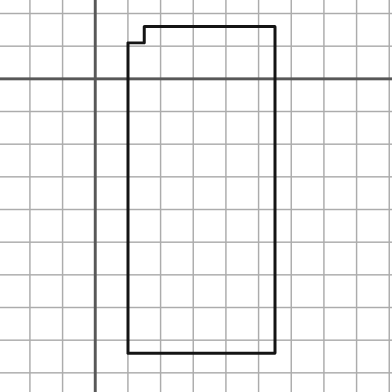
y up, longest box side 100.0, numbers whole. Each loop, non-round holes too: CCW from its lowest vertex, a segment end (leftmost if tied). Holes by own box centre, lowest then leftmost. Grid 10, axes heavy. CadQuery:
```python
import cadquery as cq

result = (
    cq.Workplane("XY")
    .moveTo(10.0, -84.0)
    .lineTo(55.0, -84.0)
    .lineTo(55.0, 16.0)
    .lineTo(15.0, 16.0)
    .lineTo(15.0, 11.0)
    .lineTo(10.0, 11.0)
    .close()
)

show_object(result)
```